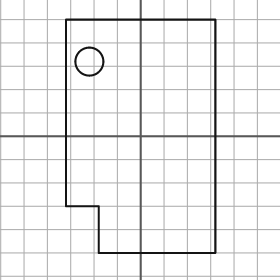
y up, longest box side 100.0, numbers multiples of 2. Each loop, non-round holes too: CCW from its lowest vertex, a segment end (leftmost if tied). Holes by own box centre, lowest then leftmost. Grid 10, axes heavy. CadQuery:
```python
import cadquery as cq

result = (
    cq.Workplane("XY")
    .moveTo(-18.0, -50.0)
    .lineTo(32.0, -50.0)
    .lineTo(32.0, 50.0)
    .lineTo(-32.0, 50.0)
    .lineTo(-32.0, -30.0)
    .lineTo(-18.0, -30.0)
    .close()
    .moveTo(-22.0, 32.0)
    .circle(6.0)
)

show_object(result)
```